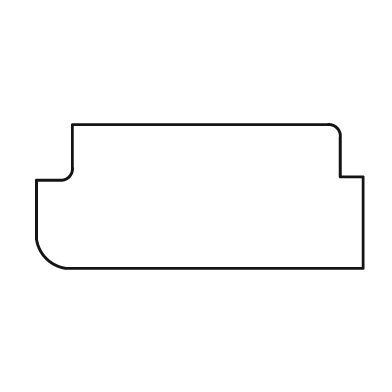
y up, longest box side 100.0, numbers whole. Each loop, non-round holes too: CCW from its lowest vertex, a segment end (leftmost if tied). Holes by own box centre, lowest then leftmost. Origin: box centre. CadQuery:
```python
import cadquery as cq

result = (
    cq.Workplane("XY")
    .moveTo(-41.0, -22.0)
    .lineTo(50.0, -22.0)
    .lineTo(50.0, 6.0)
    .lineTo(43.0, 6.0)
    .lineTo(43.0, 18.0)
    .threePointArc((42.0, 21.0), (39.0, 22.0))
    .lineTo(-39.0, 22.0)
    .lineTo(-39.0, 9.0)
    .threePointArc((-40.0, 6.0), (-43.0, 5.0))
    .lineTo(-50.0, 5.0)
    .lineTo(-50.0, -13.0)
    .threePointArc((-47.0, -19.0), (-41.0, -22.0))
    .close()
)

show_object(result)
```